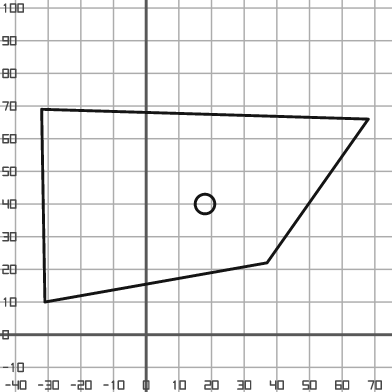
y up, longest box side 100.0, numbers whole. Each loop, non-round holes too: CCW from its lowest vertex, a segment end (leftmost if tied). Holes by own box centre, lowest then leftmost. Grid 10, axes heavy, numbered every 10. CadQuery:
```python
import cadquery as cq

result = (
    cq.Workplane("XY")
    .moveTo(-31.0, 10.0)
    .lineTo(37.0, 22.0)
    .lineTo(68.0, 66.0)
    .lineTo(-32.0, 69.0)
    .close()
    .moveTo(18.0, 40.0)
    .circle(3.0)
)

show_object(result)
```